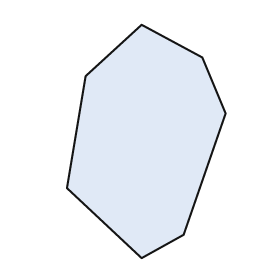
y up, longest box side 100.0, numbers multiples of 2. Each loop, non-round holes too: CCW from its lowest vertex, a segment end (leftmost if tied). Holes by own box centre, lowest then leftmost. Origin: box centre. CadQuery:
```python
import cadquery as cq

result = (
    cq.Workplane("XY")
    .moveTo(-2.0, -50.0)
    .lineTo(16.0, -40.0)
    .lineTo(34.0, 12.0)
    .lineTo(24.0, 36.0)
    .lineTo(-2.0, 50.0)
    .lineTo(-26.0, 28.0)
    .lineTo(-34.0, -20.0)
    .close()
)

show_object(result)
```